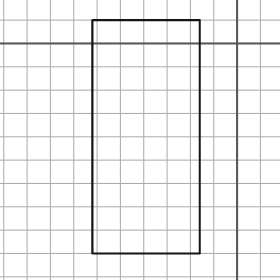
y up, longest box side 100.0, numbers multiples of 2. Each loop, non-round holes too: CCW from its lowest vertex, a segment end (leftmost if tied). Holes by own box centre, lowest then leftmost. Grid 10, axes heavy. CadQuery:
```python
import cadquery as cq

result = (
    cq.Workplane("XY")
    .moveTo(-62.0, -90.0)
    .lineTo(-16.0, -90.0)
    .lineTo(-16.0, 10.0)
    .lineTo(-62.0, 10.0)
    .close()
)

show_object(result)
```